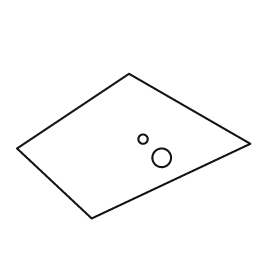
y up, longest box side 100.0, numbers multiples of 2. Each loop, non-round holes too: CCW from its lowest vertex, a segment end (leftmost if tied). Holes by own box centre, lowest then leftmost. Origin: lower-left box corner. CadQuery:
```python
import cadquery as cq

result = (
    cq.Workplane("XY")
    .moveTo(32.0, 0.0)
    .lineTo(100.0, 32.0)
    .lineTo(48.0, 62.0)
    .lineTo(0.0, 30.0)
    .close()
    .moveTo(62.0, 26.0)
    .circle(4.0)
    .moveTo(54.0, 34.0)
    .circle(2.0)
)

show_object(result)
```